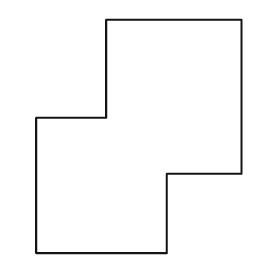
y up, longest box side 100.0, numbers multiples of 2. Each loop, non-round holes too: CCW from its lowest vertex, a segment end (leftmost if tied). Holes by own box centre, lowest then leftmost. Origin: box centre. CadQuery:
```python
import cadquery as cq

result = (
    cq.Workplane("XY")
    .moveTo(-44.0, -50.0)
    .lineTo(12.0, -50.0)
    .lineTo(12.0, -16.0)
    .lineTo(44.0, -16.0)
    .lineTo(44.0, 50.0)
    .lineTo(-14.0, 50.0)
    .lineTo(-14.0, 8.0)
    .lineTo(-44.0, 8.0)
    .close()
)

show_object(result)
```